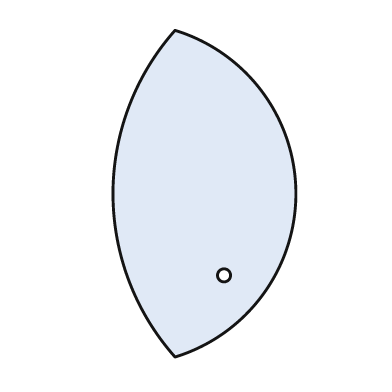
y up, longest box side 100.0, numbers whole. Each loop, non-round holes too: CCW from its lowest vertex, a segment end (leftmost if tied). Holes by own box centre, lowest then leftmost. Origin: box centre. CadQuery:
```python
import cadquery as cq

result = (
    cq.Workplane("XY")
    .moveTo(-9.0, -50.0)
    .threePointArc((28.0, 0.0), (-9.0, 50.0))
    .threePointArc((-28.0, 0.0), (-9.0, -50.0))
    .close()
    .moveTo(6.0, -25.0)
    .circle(2.0)
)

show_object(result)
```